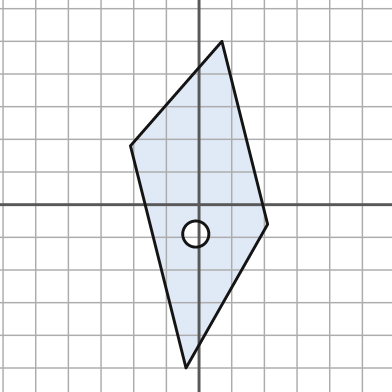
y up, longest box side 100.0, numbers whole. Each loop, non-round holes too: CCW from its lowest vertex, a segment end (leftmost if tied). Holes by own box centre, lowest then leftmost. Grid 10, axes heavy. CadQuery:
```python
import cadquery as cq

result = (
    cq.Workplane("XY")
    .moveTo(-4.0, -50.0)
    .lineTo(21.0, -6.0)
    .lineTo(7.0, 50.0)
    .lineTo(-21.0, 18.0)
    .close()
    .moveTo(-1.0, -9.0)
    .circle(4.0)
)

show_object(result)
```